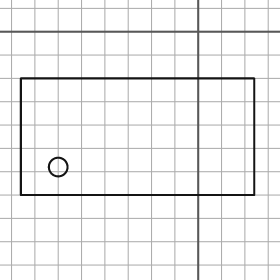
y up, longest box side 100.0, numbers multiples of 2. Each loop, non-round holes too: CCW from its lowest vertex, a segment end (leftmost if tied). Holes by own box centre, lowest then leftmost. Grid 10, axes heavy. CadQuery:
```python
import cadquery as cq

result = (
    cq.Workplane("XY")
    .moveTo(-76.0, -70.0)
    .lineTo(24.0, -70.0)
    .lineTo(24.0, -20.0)
    .lineTo(-76.0, -20.0)
    .close()
    .moveTo(-60.0, -58.0)
    .circle(4.0)
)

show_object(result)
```